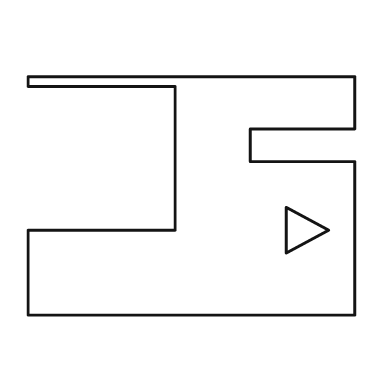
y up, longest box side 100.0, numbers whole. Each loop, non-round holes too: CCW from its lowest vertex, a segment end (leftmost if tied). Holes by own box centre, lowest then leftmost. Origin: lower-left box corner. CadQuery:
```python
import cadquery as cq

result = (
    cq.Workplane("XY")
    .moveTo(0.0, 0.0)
    .lineTo(100.0, 0.0)
    .lineTo(100.0, 47.0)
    .lineTo(68.0, 47.0)
    .lineTo(68.0, 57.0)
    .lineTo(100.0, 57.0)
    .lineTo(100.0, 73.0)
    .lineTo(0.0, 73.0)
    .lineTo(0.0, 70.0)
    .lineTo(45.0, 70.0)
    .lineTo(45.0, 26.0)
    .lineTo(0.0, 26.0)
    .close()
    .moveTo(79.0, 19.0)
    .lineTo(92.0, 26.0)
    .lineTo(79.0, 33.0)
    .close()
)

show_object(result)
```